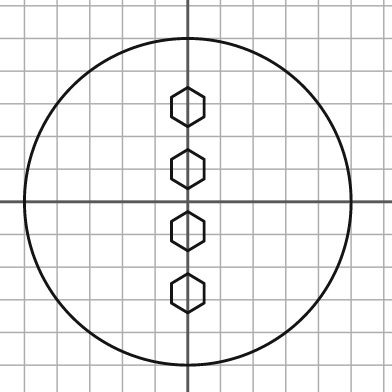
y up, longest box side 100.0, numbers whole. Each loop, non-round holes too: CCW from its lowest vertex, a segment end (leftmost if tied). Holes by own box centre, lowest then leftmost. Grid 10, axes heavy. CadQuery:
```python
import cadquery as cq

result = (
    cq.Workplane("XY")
    .moveTo(0.0, 0.0)
    .circle(50.0)
    .moveTo(0.0, -34.0)
    .lineTo(5.0, -31.0)
    .lineTo(5.0, -25.0)
    .lineTo(0.0, -22.0)
    .lineTo(-5.0, -25.0)
    .lineTo(-5.0, -31.0)
    .close()
    .moveTo(0.0, -15.0)
    .lineTo(5.0, -12.0)
    .lineTo(5.0, -6.0)
    .lineTo(0.0, -3.0)
    .lineTo(-5.0, -6.0)
    .lineTo(-5.0, -12.0)
    .close()
    .moveTo(0.0, 4.0)
    .lineTo(5.0, 7.0)
    .lineTo(5.0, 13.0)
    .lineTo(0.0, 16.0)
    .lineTo(-5.0, 13.0)
    .lineTo(-5.0, 7.0)
    .close()
    .moveTo(0.0, 23.0)
    .lineTo(5.0, 26.0)
    .lineTo(5.0, 32.0)
    .lineTo(0.0, 35.0)
    .lineTo(-5.0, 32.0)
    .lineTo(-5.0, 26.0)
    .close()
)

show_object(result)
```